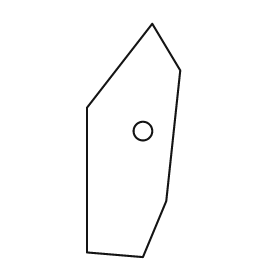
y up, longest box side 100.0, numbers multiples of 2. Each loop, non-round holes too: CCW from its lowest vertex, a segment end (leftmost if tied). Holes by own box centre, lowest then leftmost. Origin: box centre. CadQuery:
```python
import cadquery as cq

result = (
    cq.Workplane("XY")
    .moveTo(4.0, -50.0)
    .lineTo(14.0, -26.0)
    .lineTo(20.0, 30.0)
    .lineTo(8.0, 50.0)
    .lineTo(-20.0, 14.0)
    .lineTo(-20.0, -48.0)
    .close()
    .moveTo(4.0, 4.0)
    .circle(4.0)
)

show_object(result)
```